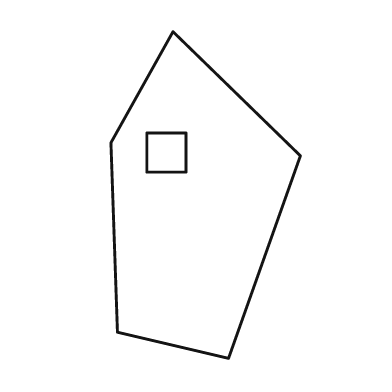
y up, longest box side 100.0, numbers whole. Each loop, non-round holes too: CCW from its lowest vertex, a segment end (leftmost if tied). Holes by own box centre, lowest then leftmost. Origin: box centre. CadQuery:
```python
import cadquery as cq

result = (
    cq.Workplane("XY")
    .moveTo(7.0, -50.0)
    .lineTo(29.0, 12.0)
    .lineTo(-10.0, 50.0)
    .lineTo(-29.0, 16.0)
    .lineTo(-27.0, -42.0)
    .close()
    .moveTo(-18.0, 7.0)
    .lineTo(-6.0, 7.0)
    .lineTo(-6.0, 19.0)
    .lineTo(-18.0, 19.0)
    .close()
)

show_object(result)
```